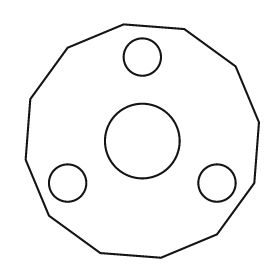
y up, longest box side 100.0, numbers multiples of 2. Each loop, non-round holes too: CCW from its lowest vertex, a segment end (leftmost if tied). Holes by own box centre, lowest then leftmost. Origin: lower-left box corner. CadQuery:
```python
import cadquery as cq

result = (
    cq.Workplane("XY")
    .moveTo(58.0, 0.0)
    .lineTo(82.0, 10.0)
    .lineTo(98.0, 32.0)
    .lineTo(100.0, 58.0)
    .lineTo(90.0, 82.0)
    .lineTo(68.0, 98.0)
    .lineTo(42.0, 100.0)
    .lineTo(18.0, 90.0)
    .lineTo(2.0, 68.0)
    .lineTo(0.0, 42.0)
    .lineTo(10.0, 18.0)
    .lineTo(32.0, 2.0)
    .close()
    .moveTo(18.0, 32.0)
    .circle(8.0)
    .moveTo(82.0, 32.0)
    .circle(8.0)
    .moveTo(50.0, 50.0)
    .circle(16.0)
    .moveTo(50.0, 86.0)
    .circle(8.0)
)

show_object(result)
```